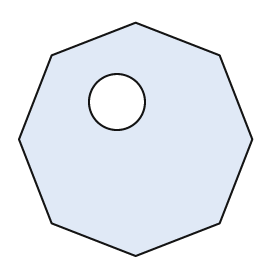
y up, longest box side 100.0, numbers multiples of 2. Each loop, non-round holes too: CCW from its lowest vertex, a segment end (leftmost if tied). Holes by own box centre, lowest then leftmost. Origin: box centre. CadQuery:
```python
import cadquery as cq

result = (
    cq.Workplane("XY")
    .moveTo(0.0, -50.0)
    .lineTo(36.0, -36.0)
    .lineTo(50.0, 0.0)
    .lineTo(36.0, 36.0)
    .lineTo(0.0, 50.0)
    .lineTo(-36.0, 36.0)
    .lineTo(-50.0, 0.0)
    .lineTo(-36.0, -36.0)
    .close()
    .moveTo(-8.0, 16.0)
    .circle(12.0)
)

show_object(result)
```